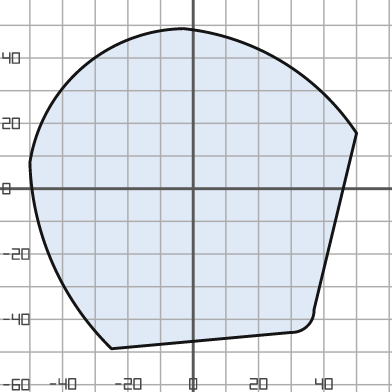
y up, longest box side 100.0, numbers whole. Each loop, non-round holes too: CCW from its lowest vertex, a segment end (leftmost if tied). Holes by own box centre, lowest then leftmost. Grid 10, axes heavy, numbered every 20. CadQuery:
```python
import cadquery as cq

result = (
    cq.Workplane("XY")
    .moveTo(-25.0, -49.0)
    .lineTo(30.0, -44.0)
    .threePointArc((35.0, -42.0), (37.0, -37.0))
    .lineTo(50.0, 17.0)
    .threePointArc((27.0, 39.0), (-3.0, 49.0))
    .threePointArc((-34.0, 37.0), (-50.0, 8.0))
    .threePointArc((-43.0, -23.0), (-25.0, -49.0))
    .close()
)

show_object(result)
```